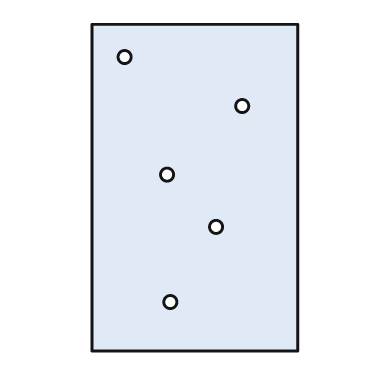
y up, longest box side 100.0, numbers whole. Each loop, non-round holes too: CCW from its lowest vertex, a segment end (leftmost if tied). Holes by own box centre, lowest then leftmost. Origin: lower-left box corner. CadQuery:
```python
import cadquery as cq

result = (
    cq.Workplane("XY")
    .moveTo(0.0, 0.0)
    .lineTo(63.0, 0.0)
    .lineTo(63.0, 100.0)
    .lineTo(0.0, 100.0)
    .close()
    .moveTo(24.0, 15.0)
    .circle(2.0)
    .moveTo(38.0, 38.0)
    .circle(2.0)
    .moveTo(23.0, 54.0)
    .circle(2.0)
    .moveTo(46.0, 75.0)
    .circle(2.0)
    .moveTo(10.0, 90.0)
    .circle(2.0)
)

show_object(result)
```